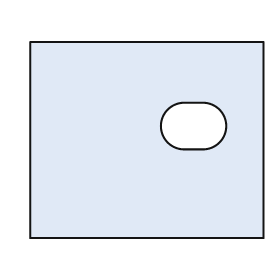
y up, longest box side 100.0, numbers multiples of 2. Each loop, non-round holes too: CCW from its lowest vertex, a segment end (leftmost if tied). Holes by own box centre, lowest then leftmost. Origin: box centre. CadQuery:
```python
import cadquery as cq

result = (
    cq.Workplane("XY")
    .moveTo(-50.0, -42.0)
    .lineTo(50.0, -42.0)
    .lineTo(50.0, 42.0)
    .lineTo(-50.0, 42.0)
    .close()
    .moveTo(16.0, -4.0)
    .lineTo(24.0, -4.0)
    .threePointArc((34.0, 6.0), (24.0, 16.0))
    .lineTo(16.0, 16.0)
    .threePointArc((6.0, 6.0), (16.0, -4.0))
    .close()
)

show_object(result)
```